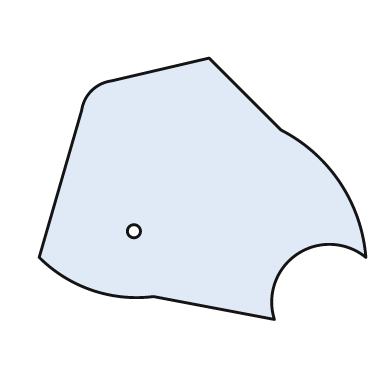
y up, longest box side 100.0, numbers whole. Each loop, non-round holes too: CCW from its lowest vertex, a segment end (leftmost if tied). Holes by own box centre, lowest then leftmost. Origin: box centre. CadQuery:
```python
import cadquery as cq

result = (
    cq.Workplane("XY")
    .moveTo(22.0, -40.0)
    .threePointArc((29.0, -20.0), (50.0, -21.0))
    .threePointArc((42.0, 2.0), (24.0, 18.0))
    .lineTo(2.0, 40.0)
    .lineTo(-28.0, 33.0)
    .threePointArc((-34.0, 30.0), (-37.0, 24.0))
    .lineTo(-50.0, -21.0)
    .threePointArc((-34.0, -31.0), (-15.0, -33.0))
    .close()
    .moveTo(-21.0, -13.0)
    .circle(2.0)
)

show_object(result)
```